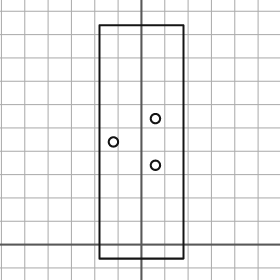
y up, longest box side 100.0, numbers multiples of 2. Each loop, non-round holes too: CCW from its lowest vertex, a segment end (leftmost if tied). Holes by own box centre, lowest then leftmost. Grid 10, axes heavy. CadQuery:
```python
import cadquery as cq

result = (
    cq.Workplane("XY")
    .moveTo(-18.0, -6.0)
    .lineTo(18.0, -6.0)
    .lineTo(18.0, 94.0)
    .lineTo(-18.0, 94.0)
    .close()
    .moveTo(6.0, 34.0)
    .circle(2.0)
    .moveTo(-12.0, 44.0)
    .circle(2.0)
    .moveTo(6.0, 54.0)
    .circle(2.0)
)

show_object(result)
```